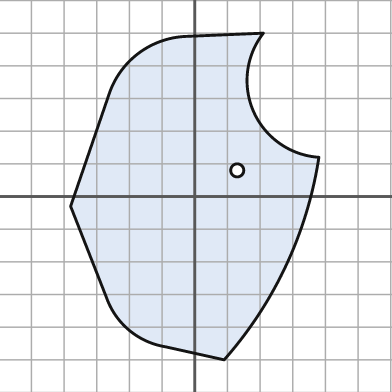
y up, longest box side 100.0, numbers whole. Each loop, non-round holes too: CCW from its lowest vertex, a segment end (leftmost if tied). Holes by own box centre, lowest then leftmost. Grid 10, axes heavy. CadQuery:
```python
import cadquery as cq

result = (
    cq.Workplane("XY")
    .moveTo(9.0, -50.0)
    .threePointArc((28.0, -21.0), (38.0, 12.0))
    .threePointArc((18.0, 26.0), (21.0, 50.0))
    .lineTo(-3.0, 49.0)
    .threePointArc((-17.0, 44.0), (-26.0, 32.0))
    .lineTo(-38.0, -3.0)
    .lineTo(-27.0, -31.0)
    .threePointArc((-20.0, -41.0), (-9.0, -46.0))
    .close()
    .moveTo(13.0, 8.0)
    .circle(2.0)
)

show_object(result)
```